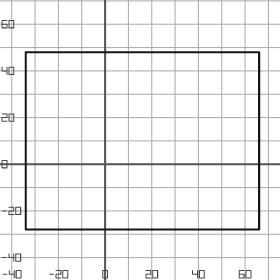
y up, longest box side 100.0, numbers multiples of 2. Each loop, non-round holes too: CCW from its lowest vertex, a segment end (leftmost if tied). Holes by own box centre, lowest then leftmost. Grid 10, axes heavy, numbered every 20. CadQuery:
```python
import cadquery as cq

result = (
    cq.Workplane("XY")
    .moveTo(-34.0, -28.0)
    .lineTo(66.0, -28.0)
    .lineTo(66.0, 48.0)
    .lineTo(-34.0, 48.0)
    .close()
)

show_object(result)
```